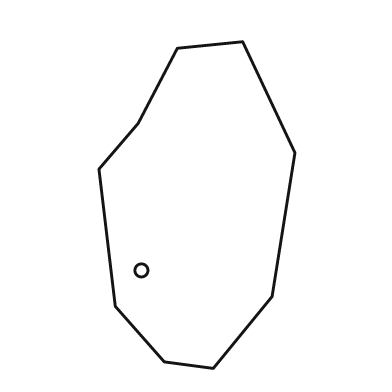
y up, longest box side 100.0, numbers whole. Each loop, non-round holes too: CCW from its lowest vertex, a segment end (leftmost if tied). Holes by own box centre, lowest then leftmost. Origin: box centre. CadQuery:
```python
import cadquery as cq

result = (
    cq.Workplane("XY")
    .moveTo(5.0, -50.0)
    .lineTo(23.0, -28.0)
    .lineTo(30.0, 16.0)
    .lineTo(14.0, 50.0)
    .lineTo(-6.0, 48.0)
    .lineTo(-18.0, 25.0)
    .lineTo(-30.0, 11.0)
    .lineTo(-25.0, -31.0)
    .lineTo(-10.0, -48.0)
    .close()
    .moveTo(-17.0, -20.0)
    .circle(2.0)
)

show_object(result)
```